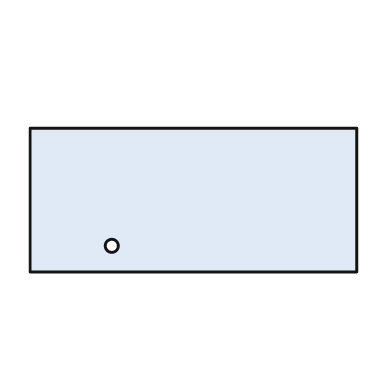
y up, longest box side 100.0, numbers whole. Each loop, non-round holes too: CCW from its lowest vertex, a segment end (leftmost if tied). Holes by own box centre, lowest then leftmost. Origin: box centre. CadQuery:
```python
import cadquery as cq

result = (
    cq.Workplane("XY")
    .moveTo(-50.0, -22.0)
    .lineTo(50.0, -22.0)
    .lineTo(50.0, 22.0)
    .lineTo(-50.0, 22.0)
    .close()
    .moveTo(-25.0, -14.0)
    .circle(2.0)
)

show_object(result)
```